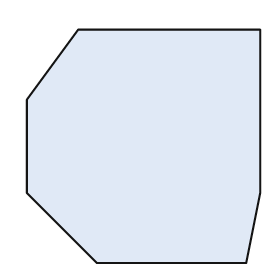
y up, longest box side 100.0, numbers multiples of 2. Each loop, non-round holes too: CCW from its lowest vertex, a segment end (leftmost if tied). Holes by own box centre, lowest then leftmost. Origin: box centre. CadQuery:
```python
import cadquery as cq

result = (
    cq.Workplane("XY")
    .moveTo(-20.0, -50.0)
    .lineTo(44.0, -50.0)
    .lineTo(50.0, -20.0)
    .lineTo(50.0, 50.0)
    .lineTo(-28.0, 50.0)
    .lineTo(-50.0, 20.0)
    .lineTo(-50.0, -20.0)
    .close()
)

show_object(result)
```